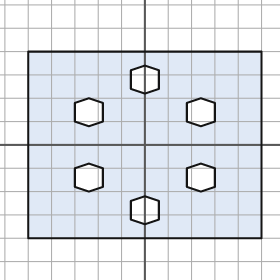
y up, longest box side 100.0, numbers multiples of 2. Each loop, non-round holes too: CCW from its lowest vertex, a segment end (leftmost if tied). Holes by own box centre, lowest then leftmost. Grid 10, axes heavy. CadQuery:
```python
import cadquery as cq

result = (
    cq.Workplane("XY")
    .moveTo(-50.0, -40.0)
    .lineTo(50.0, -40.0)
    .lineTo(50.0, 40.0)
    .lineTo(-50.0, 40.0)
    .close()
    .moveTo(0.0, -34.0)
    .lineTo(6.0, -32.0)
    .lineTo(6.0, -24.0)
    .lineTo(0.0, -22.0)
    .lineTo(-6.0, -24.0)
    .lineTo(-6.0, -32.0)
    .close()
    .moveTo(-24.0, -20.0)
    .lineTo(-18.0, -18.0)
    .lineTo(-18.0, -10.0)
    .lineTo(-24.0, -8.0)
    .lineTo(-30.0, -10.0)
    .lineTo(-30.0, -18.0)
    .close()
    .moveTo(24.0, -20.0)
    .lineTo(30.0, -18.0)
    .lineTo(30.0, -10.0)
    .lineTo(24.0, -8.0)
    .lineTo(18.0, -10.0)
    .lineTo(18.0, -18.0)
    .close()
    .moveTo(-24.0, 8.0)
    .lineTo(-18.0, 10.0)
    .lineTo(-18.0, 18.0)
    .lineTo(-24.0, 20.0)
    .lineTo(-30.0, 18.0)
    .lineTo(-30.0, 10.0)
    .close()
    .moveTo(24.0, 8.0)
    .lineTo(30.0, 10.0)
    .lineTo(30.0, 18.0)
    .lineTo(24.0, 20.0)
    .lineTo(18.0, 18.0)
    .lineTo(18.0, 10.0)
    .close()
    .moveTo(0.0, 22.0)
    .lineTo(6.0, 24.0)
    .lineTo(6.0, 32.0)
    .lineTo(0.0, 34.0)
    .lineTo(-6.0, 32.0)
    .lineTo(-6.0, 24.0)
    .close()
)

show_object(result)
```